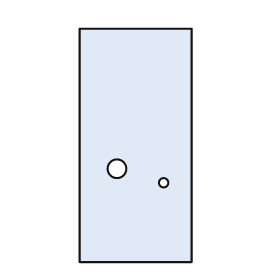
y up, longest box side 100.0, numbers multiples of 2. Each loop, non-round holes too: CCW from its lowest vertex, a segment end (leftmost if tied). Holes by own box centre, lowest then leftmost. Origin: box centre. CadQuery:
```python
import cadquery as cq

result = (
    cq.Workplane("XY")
    .moveTo(-24.0, -50.0)
    .lineTo(24.0, -50.0)
    .lineTo(24.0, 50.0)
    .lineTo(-24.0, 50.0)
    .close()
    .moveTo(12.0, -16.0)
    .circle(2.0)
    .moveTo(-8.0, -10.0)
    .circle(4.0)
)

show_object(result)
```